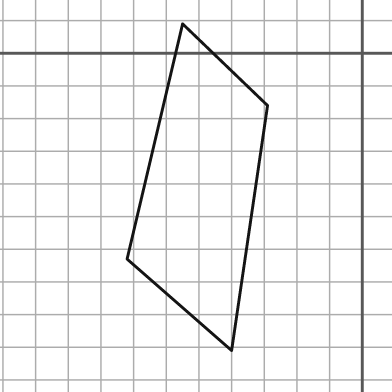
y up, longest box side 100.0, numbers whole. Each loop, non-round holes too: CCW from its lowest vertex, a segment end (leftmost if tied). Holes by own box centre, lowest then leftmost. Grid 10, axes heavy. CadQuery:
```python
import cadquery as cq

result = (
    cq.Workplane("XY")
    .moveTo(-40.0, -91.0)
    .lineTo(-29.0, -16.0)
    .lineTo(-55.0, 9.0)
    .lineTo(-72.0, -63.0)
    .close()
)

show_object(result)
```